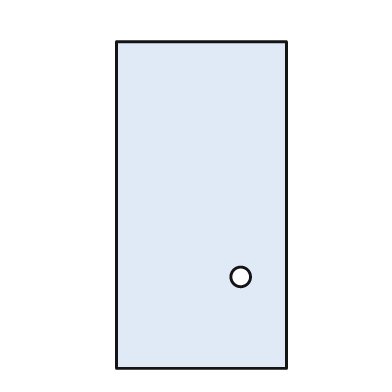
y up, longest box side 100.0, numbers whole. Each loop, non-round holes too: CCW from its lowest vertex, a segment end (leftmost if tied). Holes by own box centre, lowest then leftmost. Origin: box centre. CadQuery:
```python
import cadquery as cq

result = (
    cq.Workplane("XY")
    .moveTo(-26.0, -50.0)
    .lineTo(26.0, -50.0)
    .lineTo(26.0, 50.0)
    .lineTo(-26.0, 50.0)
    .close()
    .moveTo(12.0, -22.0)
    .circle(3.0)
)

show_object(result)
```